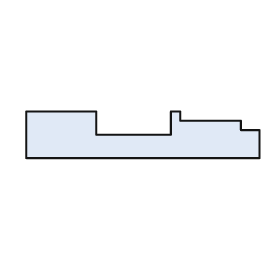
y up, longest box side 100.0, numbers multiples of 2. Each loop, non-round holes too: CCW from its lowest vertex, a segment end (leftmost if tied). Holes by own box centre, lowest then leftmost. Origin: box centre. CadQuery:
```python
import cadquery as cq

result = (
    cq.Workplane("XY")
    .moveTo(-50.0, -10.0)
    .lineTo(50.0, -10.0)
    .lineTo(50.0, 2.0)
    .lineTo(42.0, 2.0)
    .lineTo(42.0, 6.0)
    .lineTo(16.0, 6.0)
    .lineTo(16.0, 10.0)
    .lineTo(12.0, 10.0)
    .lineTo(12.0, 0.0)
    .lineTo(-20.0, 0.0)
    .lineTo(-20.0, 10.0)
    .lineTo(-50.0, 10.0)
    .close()
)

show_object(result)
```